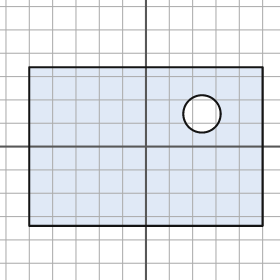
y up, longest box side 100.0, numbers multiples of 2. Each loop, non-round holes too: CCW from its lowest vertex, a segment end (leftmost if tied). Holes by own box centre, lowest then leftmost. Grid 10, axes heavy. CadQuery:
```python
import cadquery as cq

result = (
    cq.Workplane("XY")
    .moveTo(-50.0, -34.0)
    .lineTo(50.0, -34.0)
    .lineTo(50.0, 34.0)
    .lineTo(-50.0, 34.0)
    .close()
    .moveTo(24.0, 14.0)
    .circle(8.0)
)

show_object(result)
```